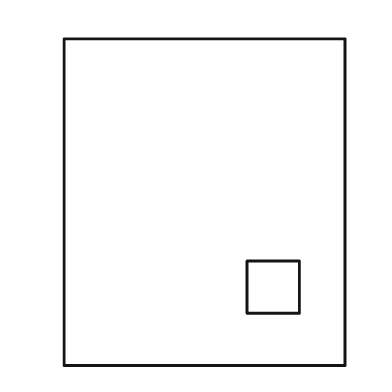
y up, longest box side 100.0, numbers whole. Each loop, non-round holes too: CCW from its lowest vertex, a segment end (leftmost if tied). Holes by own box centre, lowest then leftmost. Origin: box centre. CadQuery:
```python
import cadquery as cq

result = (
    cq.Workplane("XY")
    .moveTo(-43.0, -50.0)
    .lineTo(43.0, -50.0)
    .lineTo(43.0, 50.0)
    .lineTo(-43.0, 50.0)
    .close()
    .moveTo(13.0, -34.0)
    .lineTo(29.0, -34.0)
    .lineTo(29.0, -18.0)
    .lineTo(13.0, -18.0)
    .close()
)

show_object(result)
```